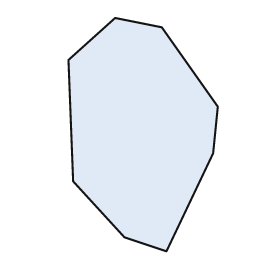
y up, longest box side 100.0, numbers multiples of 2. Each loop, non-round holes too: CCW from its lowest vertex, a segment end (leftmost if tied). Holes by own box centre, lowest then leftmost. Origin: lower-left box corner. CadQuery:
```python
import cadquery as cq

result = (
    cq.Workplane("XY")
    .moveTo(42.0, 0.0)
    .lineTo(62.0, 42.0)
    .lineTo(64.0, 62.0)
    .lineTo(40.0, 96.0)
    .lineTo(20.0, 100.0)
    .lineTo(0.0, 82.0)
    .lineTo(2.0, 30.0)
    .lineTo(24.0, 6.0)
    .close()
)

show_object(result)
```